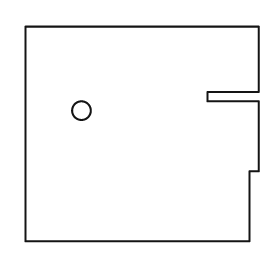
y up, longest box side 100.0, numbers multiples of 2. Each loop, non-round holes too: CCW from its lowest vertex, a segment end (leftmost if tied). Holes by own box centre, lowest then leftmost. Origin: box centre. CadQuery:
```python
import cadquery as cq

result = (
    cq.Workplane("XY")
    .moveTo(-50.0, -46.0)
    .lineTo(46.0, -46.0)
    .lineTo(46.0, -16.0)
    .lineTo(50.0, -16.0)
    .lineTo(50.0, 14.0)
    .lineTo(28.0, 14.0)
    .lineTo(28.0, 18.0)
    .lineTo(50.0, 18.0)
    .lineTo(50.0, 46.0)
    .lineTo(-50.0, 46.0)
    .close()
    .moveTo(-26.0, 10.0)
    .circle(4.0)
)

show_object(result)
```